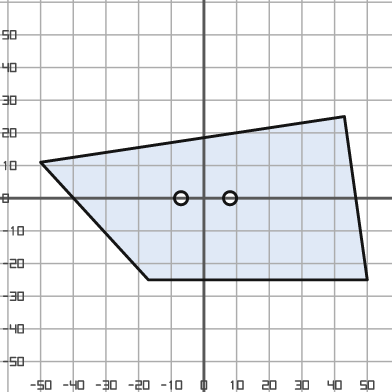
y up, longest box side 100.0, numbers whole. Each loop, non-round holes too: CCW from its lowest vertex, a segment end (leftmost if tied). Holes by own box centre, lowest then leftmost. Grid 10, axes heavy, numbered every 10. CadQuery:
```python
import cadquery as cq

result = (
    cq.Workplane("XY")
    .moveTo(-17.0, -25.0)
    .lineTo(50.0, -25.0)
    .lineTo(43.0, 25.0)
    .lineTo(-50.0, 11.0)
    .close()
    .moveTo(-7.0, 0.0)
    .circle(2.0)
    .moveTo(8.0, 0.0)
    .circle(2.0)
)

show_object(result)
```